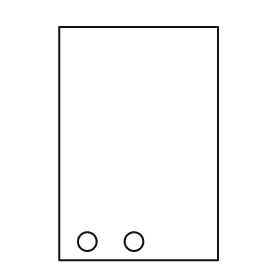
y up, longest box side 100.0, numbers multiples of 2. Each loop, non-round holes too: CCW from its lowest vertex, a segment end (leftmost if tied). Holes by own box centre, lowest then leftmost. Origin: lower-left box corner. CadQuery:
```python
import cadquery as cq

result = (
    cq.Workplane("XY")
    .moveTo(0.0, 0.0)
    .lineTo(68.0, 0.0)
    .lineTo(68.0, 100.0)
    .lineTo(0.0, 100.0)
    .close()
    .moveTo(12.0, 8.0)
    .circle(4.0)
    .moveTo(32.0, 8.0)
    .circle(4.0)
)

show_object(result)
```